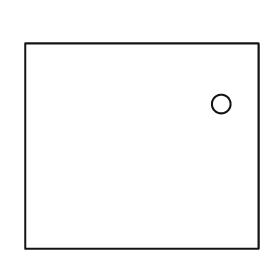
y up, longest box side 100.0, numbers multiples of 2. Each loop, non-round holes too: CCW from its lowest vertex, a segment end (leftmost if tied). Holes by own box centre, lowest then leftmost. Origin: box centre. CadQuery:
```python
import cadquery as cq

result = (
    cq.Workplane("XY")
    .moveTo(-50.0, -44.0)
    .lineTo(50.0, -44.0)
    .lineTo(50.0, 44.0)
    .lineTo(-50.0, 44.0)
    .close()
    .moveTo(34.0, 18.0)
    .circle(4.0)
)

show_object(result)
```